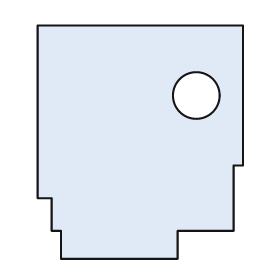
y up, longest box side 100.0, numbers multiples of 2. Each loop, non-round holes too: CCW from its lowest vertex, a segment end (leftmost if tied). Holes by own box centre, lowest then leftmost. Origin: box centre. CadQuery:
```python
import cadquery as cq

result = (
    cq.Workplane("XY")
    .moveTo(-34.0, -50.0)
    .lineTo(16.0, -50.0)
    .lineTo(16.0, -38.0)
    .lineTo(40.0, -38.0)
    .lineTo(40.0, -10.0)
    .lineTo(44.0, -10.0)
    .lineTo(44.0, 50.0)
    .lineTo(-44.0, 50.0)
    .lineTo(-44.0, -24.0)
    .lineTo(-38.0, -24.0)
    .lineTo(-38.0, -38.0)
    .lineTo(-34.0, -38.0)
    .close()
    .moveTo(24.0, 20.0)
    .circle(10.0)
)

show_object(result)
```